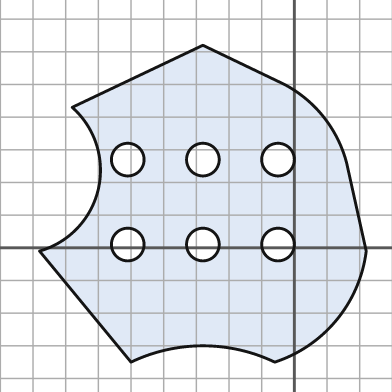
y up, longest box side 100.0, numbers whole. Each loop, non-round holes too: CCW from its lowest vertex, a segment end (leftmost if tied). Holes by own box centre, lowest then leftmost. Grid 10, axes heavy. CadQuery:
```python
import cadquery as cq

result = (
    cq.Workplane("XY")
    .moveTo(-50.0, -35.0)
    .threePointArc((-28.0, -30.0), (-6.0, -35.0))
    .threePointArc((13.0, -22.0), (22.0, -1.0))
    .lineTo(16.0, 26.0)
    .threePointArc((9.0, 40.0), (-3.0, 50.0))
    .lineTo(-28.0, 62.0)
    .lineTo(-68.0, 43.0)
    .threePointArc((-60.0, 18.0), (-78.0, -1.0))
    .close()
    .moveTo(-51.0, 1.0)
    .circle(5.0)
    .moveTo(-28.0, 1.0)
    .circle(5.0)
    .moveTo(-5.0, 1.0)
    .circle(5.0)
    .moveTo(-51.0, 27.0)
    .circle(5.0)
    .moveTo(-28.0, 27.0)
    .circle(5.0)
    .moveTo(-5.0, 27.0)
    .circle(5.0)
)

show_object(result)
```